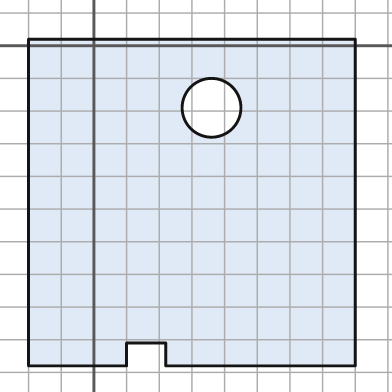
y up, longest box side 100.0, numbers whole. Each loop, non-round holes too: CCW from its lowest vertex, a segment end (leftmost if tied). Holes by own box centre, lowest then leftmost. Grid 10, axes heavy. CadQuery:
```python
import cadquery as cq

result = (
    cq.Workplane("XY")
    .moveTo(-20.0, -98.0)
    .lineTo(10.0, -98.0)
    .lineTo(10.0, -91.0)
    .lineTo(22.0, -91.0)
    .lineTo(22.0, -98.0)
    .lineTo(80.0, -98.0)
    .lineTo(80.0, 2.0)
    .lineTo(-20.0, 2.0)
    .close()
    .moveTo(36.0, -19.0)
    .circle(9.0)
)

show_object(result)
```